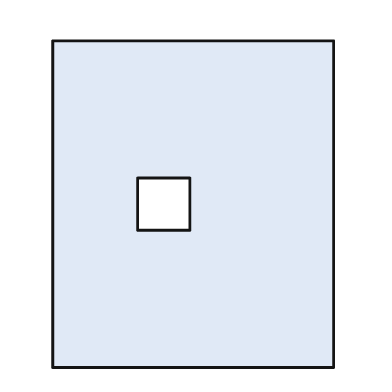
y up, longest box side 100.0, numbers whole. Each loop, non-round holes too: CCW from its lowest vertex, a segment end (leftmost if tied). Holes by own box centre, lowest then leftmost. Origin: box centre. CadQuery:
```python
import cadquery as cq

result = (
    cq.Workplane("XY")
    .moveTo(-43.0, -50.0)
    .lineTo(43.0, -50.0)
    .lineTo(43.0, 50.0)
    .lineTo(-43.0, 50.0)
    .close()
    .moveTo(-17.0, -8.0)
    .lineTo(-1.0, -8.0)
    .lineTo(-1.0, 8.0)
    .lineTo(-17.0, 8.0)
    .close()
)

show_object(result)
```